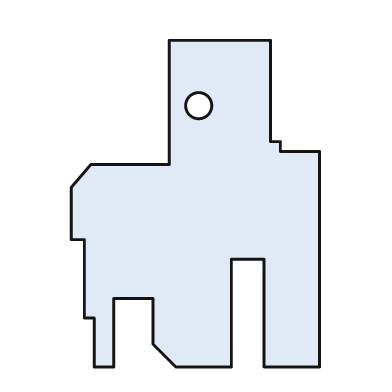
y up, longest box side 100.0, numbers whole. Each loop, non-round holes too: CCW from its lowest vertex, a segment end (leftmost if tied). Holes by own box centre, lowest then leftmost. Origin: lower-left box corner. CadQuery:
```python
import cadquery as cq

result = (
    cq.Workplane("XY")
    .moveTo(7.0, 0.0)
    .lineTo(13.0, 0.0)
    .lineTo(13.0, 21.0)
    .lineTo(25.0, 21.0)
    .lineTo(25.0, 7.0)
    .lineTo(32.0, 0.0)
    .lineTo(49.0, 0.0)
    .lineTo(49.0, 33.0)
    .lineTo(59.0, 33.0)
    .lineTo(59.0, 0.0)
    .lineTo(76.0, 0.0)
    .lineTo(76.0, 66.0)
    .lineTo(64.0, 66.0)
    .lineTo(64.0, 69.0)
    .lineTo(61.0, 69.0)
    .lineTo(61.0, 100.0)
    .lineTo(30.0, 100.0)
    .lineTo(30.0, 62.0)
    .lineTo(6.0, 62.0)
    .lineTo(0.0, 55.0)
    .lineTo(0.0, 39.0)
    .lineTo(4.0, 39.0)
    .lineTo(4.0, 15.0)
    .lineTo(7.0, 15.0)
    .close()
    .moveTo(39.0, 80.0)
    .circle(4.0)
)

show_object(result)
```